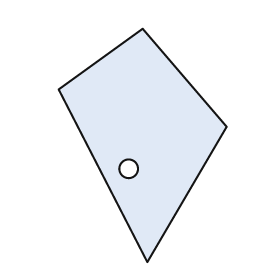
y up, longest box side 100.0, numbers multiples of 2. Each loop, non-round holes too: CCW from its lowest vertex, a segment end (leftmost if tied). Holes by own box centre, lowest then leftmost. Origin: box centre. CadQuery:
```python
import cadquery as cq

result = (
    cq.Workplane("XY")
    .moveTo(2.0, -50.0)
    .lineTo(36.0, 8.0)
    .lineTo(0.0, 50.0)
    .lineTo(-36.0, 24.0)
    .close()
    .moveTo(-6.0, -10.0)
    .circle(4.0)
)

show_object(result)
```